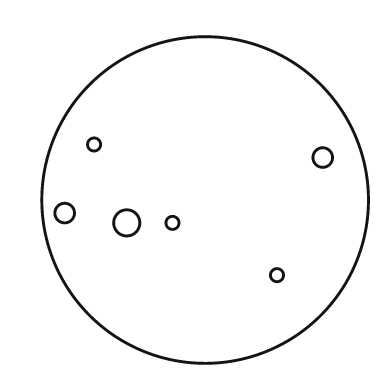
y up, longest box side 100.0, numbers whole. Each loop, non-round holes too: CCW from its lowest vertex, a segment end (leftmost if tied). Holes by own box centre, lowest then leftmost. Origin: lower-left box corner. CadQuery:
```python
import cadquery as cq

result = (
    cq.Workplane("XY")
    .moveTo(50.0, 50.0)
    .circle(50.0)
    .moveTo(72.0, 27.0)
    .circle(2.0)
    .moveTo(26.0, 43.0)
    .circle(4.0)
    .moveTo(40.0, 43.0)
    .circle(2.0)
    .moveTo(7.0, 46.0)
    .circle(3.0)
    .moveTo(86.0, 63.0)
    .circle(3.0)
    .moveTo(16.0, 67.0)
    .circle(2.0)
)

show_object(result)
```